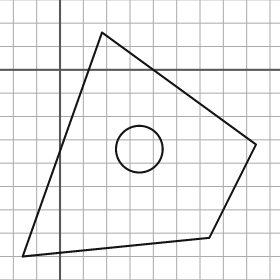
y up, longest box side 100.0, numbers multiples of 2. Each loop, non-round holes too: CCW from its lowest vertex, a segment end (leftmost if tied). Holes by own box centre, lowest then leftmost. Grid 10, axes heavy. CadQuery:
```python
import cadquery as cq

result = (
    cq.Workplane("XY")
    .moveTo(-16.0, -80.0)
    .lineTo(64.0, -72.0)
    .lineTo(84.0, -32.0)
    .lineTo(18.0, 16.0)
    .close()
    .moveTo(34.0, -34.0)
    .circle(10.0)
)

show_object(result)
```